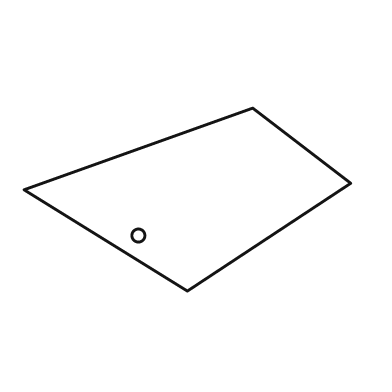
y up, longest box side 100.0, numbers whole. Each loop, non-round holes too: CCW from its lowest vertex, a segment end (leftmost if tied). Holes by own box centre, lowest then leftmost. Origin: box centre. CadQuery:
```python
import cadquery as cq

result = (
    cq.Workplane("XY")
    .moveTo(0.0, -28.0)
    .lineTo(50.0, 5.0)
    .lineTo(20.0, 28.0)
    .lineTo(-50.0, 3.0)
    .close()
    .moveTo(-15.0, -11.0)
    .circle(2.0)
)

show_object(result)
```